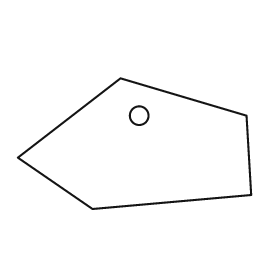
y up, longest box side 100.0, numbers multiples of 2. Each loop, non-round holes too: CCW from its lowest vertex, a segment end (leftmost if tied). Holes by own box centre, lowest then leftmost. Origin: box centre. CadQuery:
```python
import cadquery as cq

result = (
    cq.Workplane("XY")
    .moveTo(-18.0, -28.0)
    .lineTo(50.0, -22.0)
    .lineTo(48.0, 12.0)
    .lineTo(-6.0, 28.0)
    .lineTo(-50.0, -6.0)
    .close()
    .moveTo(2.0, 12.0)
    .circle(4.0)
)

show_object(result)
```